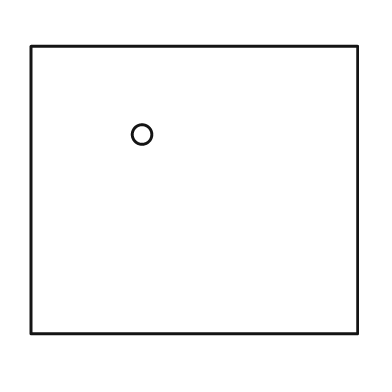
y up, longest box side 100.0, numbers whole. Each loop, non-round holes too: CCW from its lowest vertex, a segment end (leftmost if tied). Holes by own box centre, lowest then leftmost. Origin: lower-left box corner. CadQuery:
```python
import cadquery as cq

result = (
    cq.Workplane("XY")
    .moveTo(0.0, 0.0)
    .lineTo(100.0, 0.0)
    .lineTo(100.0, 88.0)
    .lineTo(0.0, 88.0)
    .close()
    .moveTo(34.0, 61.0)
    .circle(3.0)
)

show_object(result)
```